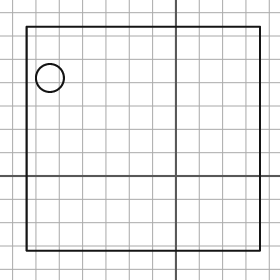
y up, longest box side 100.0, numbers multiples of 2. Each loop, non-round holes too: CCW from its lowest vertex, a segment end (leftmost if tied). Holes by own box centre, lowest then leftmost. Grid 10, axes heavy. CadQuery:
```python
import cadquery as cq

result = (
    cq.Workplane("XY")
    .moveTo(-64.0, -32.0)
    .lineTo(36.0, -32.0)
    .lineTo(36.0, 64.0)
    .lineTo(-64.0, 64.0)
    .close()
    .moveTo(-54.0, 42.0)
    .circle(6.0)
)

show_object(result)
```